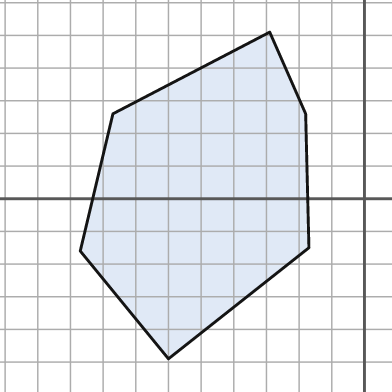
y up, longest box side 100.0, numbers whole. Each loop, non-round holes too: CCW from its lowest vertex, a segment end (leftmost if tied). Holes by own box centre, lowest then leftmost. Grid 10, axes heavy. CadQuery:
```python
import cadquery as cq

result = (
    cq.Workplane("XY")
    .moveTo(-60.0, -49.0)
    .lineTo(-17.0, -15.0)
    .lineTo(-18.0, 26.0)
    .lineTo(-29.0, 51.0)
    .lineTo(-77.0, 26.0)
    .lineTo(-87.0, -16.0)
    .close()
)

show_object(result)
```